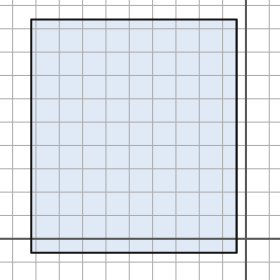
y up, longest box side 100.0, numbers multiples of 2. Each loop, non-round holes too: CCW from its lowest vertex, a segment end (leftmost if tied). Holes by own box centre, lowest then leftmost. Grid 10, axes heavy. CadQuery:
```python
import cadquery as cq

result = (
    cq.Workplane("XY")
    .moveTo(-92.0, -6.0)
    .lineTo(-4.0, -6.0)
    .lineTo(-4.0, 94.0)
    .lineTo(-92.0, 94.0)
    .close()
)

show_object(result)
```